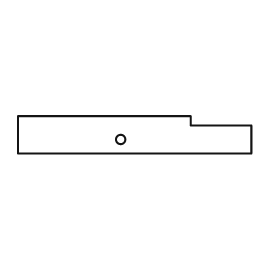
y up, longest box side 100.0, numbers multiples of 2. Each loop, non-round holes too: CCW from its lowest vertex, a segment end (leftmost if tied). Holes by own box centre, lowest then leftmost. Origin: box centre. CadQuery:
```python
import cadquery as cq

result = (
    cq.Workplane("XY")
    .moveTo(-50.0, -8.0)
    .lineTo(50.0, -8.0)
    .lineTo(50.0, 4.0)
    .lineTo(24.0, 4.0)
    .lineTo(24.0, 8.0)
    .lineTo(-50.0, 8.0)
    .close()
    .moveTo(-6.0, -2.0)
    .circle(2.0)
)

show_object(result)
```